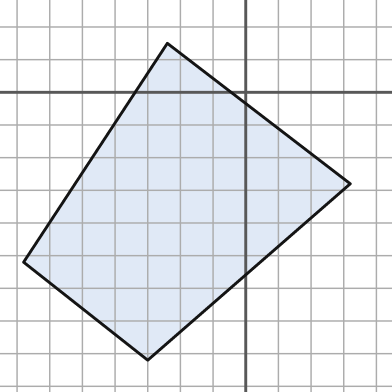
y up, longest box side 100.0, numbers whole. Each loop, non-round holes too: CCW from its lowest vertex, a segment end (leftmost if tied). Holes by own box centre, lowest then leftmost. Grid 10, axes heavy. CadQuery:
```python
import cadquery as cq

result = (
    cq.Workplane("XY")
    .moveTo(-30.0, -82.0)
    .lineTo(32.0, -28.0)
    .lineTo(-24.0, 15.0)
    .lineTo(-68.0, -52.0)
    .close()
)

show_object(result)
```